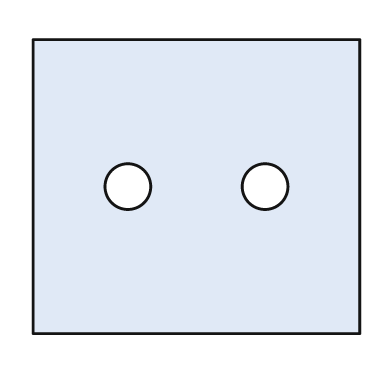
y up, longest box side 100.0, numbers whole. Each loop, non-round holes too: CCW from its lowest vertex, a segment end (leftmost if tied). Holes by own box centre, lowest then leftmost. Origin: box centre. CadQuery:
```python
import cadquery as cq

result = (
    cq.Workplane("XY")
    .moveTo(-50.0, -45.0)
    .lineTo(50.0, -45.0)
    .lineTo(50.0, 45.0)
    .lineTo(-50.0, 45.0)
    .close()
    .moveTo(-21.0, 0.0)
    .circle(7.0)
    .moveTo(21.0, 0.0)
    .circle(7.0)
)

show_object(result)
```